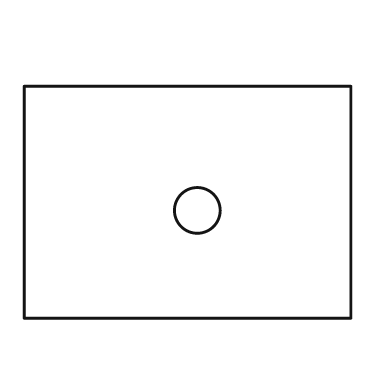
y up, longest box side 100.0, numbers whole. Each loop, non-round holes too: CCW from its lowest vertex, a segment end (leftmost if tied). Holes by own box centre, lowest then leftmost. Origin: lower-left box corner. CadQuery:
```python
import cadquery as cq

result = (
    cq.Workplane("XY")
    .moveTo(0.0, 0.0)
    .lineTo(100.0, 0.0)
    .lineTo(100.0, 71.0)
    .lineTo(0.0, 71.0)
    .close()
    .moveTo(53.0, 33.0)
    .circle(7.0)
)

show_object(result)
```